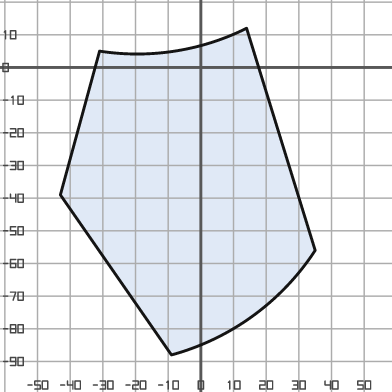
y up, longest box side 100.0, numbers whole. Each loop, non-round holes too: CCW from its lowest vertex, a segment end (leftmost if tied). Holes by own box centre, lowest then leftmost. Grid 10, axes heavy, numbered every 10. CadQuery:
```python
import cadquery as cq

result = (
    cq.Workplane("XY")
    .moveTo(-9.0, -88.0)
    .threePointArc((16.0, -76.0), (35.0, -56.0))
    .lineTo(14.0, 12.0)
    .threePointArc((-8.0, 5.0), (-31.0, 5.0))
    .lineTo(-43.0, -39.0)
    .close()
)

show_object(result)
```